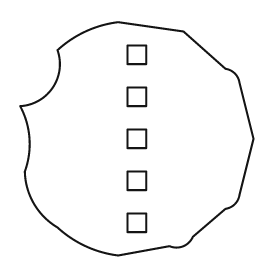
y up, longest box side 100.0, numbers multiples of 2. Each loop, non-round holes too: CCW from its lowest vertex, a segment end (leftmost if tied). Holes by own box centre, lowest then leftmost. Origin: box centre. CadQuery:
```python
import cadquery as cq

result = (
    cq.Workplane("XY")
    .moveTo(-8.0, -50.0)
    .lineTo(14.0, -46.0)
    .threePointArc((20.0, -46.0), (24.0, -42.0))
    .lineTo(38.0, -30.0)
    .threePointArc((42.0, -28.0), (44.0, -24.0))
    .lineTo(50.0, 0.0)
    .lineTo(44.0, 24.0)
    .threePointArc((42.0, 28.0), (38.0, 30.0))
    .lineTo(20.0, 46.0)
    .lineTo(-8.0, 50.0)
    .threePointArc((-22.0, 46.0), (-34.0, 38.0))
    .threePointArc((-36.0, 22.0), (-50.0, 14.0))
    .threePointArc((-46.0, 0.0), (-48.0, -14.0))
    .threePointArc((-44.0, -28.0), (-34.0, -38.0))
    .threePointArc((-22.0, -46.0), (-8.0, -50.0))
    .close()
    .moveTo(-4.0, -40.0)
    .lineTo(4.0, -40.0)
    .lineTo(4.0, -32.0)
    .lineTo(-4.0, -32.0)
    .close()
    .moveTo(-4.0, -22.0)
    .lineTo(4.0, -22.0)
    .lineTo(4.0, -14.0)
    .lineTo(-4.0, -14.0)
    .close()
    .moveTo(-4.0, -4.0)
    .lineTo(4.0, -4.0)
    .lineTo(4.0, 4.0)
    .lineTo(-4.0, 4.0)
    .close()
    .moveTo(-4.0, 14.0)
    .lineTo(4.0, 14.0)
    .lineTo(4.0, 22.0)
    .lineTo(-4.0, 22.0)
    .close()
    .moveTo(-4.0, 32.0)
    .lineTo(4.0, 32.0)
    .lineTo(4.0, 40.0)
    .lineTo(-4.0, 40.0)
    .close()
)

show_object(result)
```